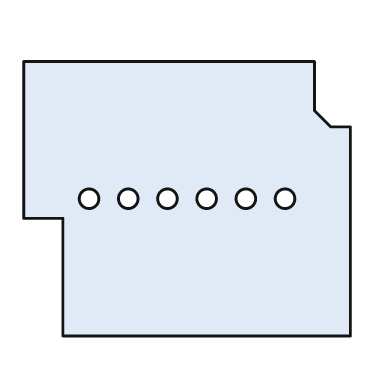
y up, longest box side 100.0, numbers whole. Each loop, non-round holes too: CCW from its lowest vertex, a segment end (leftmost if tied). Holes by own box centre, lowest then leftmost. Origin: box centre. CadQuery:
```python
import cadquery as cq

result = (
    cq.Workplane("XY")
    .moveTo(-38.0, -42.0)
    .lineTo(50.0, -42.0)
    .lineTo(50.0, 22.0)
    .lineTo(44.0, 22.0)
    .lineTo(39.0, 27.0)
    .lineTo(39.0, 42.0)
    .lineTo(-50.0, 42.0)
    .lineTo(-50.0, -6.0)
    .lineTo(-38.0, -6.0)
    .close()
    .moveTo(-30.0, 0.0)
    .circle(3.0)
    .moveTo(-18.0, 0.0)
    .circle(3.0)
    .moveTo(-6.0, 0.0)
    .circle(3.0)
    .moveTo(6.0, 0.0)
    .circle(3.0)
    .moveTo(18.0, 0.0)
    .circle(3.0)
    .moveTo(30.0, 0.0)
    .circle(3.0)
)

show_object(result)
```